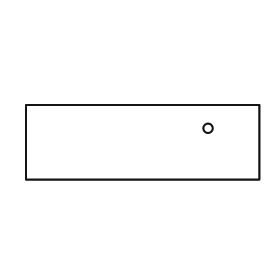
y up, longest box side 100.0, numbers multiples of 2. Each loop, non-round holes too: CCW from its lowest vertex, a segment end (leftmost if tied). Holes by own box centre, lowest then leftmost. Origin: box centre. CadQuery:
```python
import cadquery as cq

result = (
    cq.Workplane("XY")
    .moveTo(-50.0, -16.0)
    .lineTo(50.0, -16.0)
    .lineTo(50.0, 16.0)
    .lineTo(-50.0, 16.0)
    .close()
    .moveTo(28.0, 6.0)
    .circle(2.0)
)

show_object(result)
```